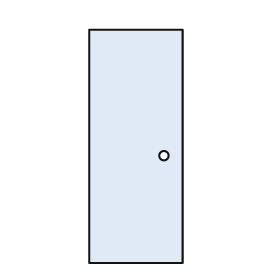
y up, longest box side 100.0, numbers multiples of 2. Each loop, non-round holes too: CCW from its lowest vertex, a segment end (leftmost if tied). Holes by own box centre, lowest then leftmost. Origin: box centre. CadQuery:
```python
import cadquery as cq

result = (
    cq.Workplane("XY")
    .moveTo(-20.0, -50.0)
    .lineTo(20.0, -50.0)
    .lineTo(20.0, 50.0)
    .lineTo(-20.0, 50.0)
    .close()
    .moveTo(12.0, -4.0)
    .circle(2.0)
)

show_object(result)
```